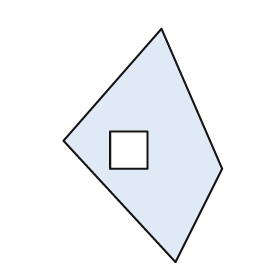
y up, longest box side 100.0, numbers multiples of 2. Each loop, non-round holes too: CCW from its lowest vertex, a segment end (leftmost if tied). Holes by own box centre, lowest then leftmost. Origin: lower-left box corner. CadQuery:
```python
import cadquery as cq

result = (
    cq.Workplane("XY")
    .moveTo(48.0, 0.0)
    .lineTo(68.0, 40.0)
    .lineTo(42.0, 100.0)
    .lineTo(0.0, 52.0)
    .close()
    .moveTo(20.0, 40.0)
    .lineTo(36.0, 40.0)
    .lineTo(36.0, 56.0)
    .lineTo(20.0, 56.0)
    .close()
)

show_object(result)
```